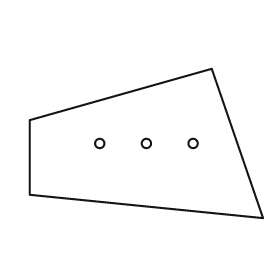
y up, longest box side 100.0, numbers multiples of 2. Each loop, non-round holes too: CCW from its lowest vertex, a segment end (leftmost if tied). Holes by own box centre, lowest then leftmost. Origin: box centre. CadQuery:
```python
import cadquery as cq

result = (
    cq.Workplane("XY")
    .moveTo(50.0, -32.0)
    .lineTo(28.0, 32.0)
    .lineTo(-50.0, 10.0)
    .lineTo(-50.0, -22.0)
    .close()
    .moveTo(-20.0, 0.0)
    .circle(2.0)
    .moveTo(0.0, 0.0)
    .circle(2.0)
    .moveTo(20.0, 0.0)
    .circle(2.0)
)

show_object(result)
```